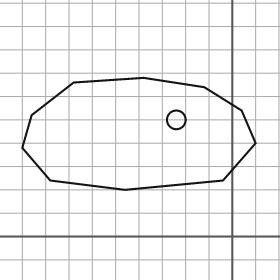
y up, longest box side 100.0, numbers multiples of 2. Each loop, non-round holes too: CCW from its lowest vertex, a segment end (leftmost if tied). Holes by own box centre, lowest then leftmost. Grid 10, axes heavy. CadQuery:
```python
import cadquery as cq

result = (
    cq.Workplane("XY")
    .moveTo(-46.0, 20.0)
    .lineTo(-4.0, 24.0)
    .lineTo(10.0, 40.0)
    .lineTo(4.0, 54.0)
    .lineTo(-12.0, 64.0)
    .lineTo(-38.0, 68.0)
    .lineTo(-68.0, 66.0)
    .lineTo(-86.0, 52.0)
    .lineTo(-90.0, 38.0)
    .lineTo(-78.0, 24.0)
    .close()
    .moveTo(-24.0, 50.0)
    .circle(4.0)
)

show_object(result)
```